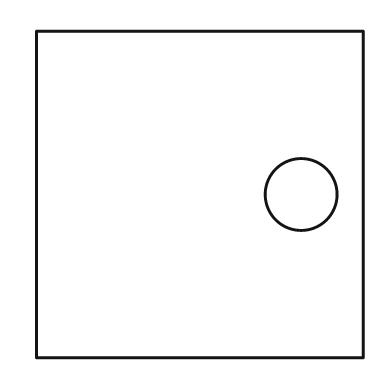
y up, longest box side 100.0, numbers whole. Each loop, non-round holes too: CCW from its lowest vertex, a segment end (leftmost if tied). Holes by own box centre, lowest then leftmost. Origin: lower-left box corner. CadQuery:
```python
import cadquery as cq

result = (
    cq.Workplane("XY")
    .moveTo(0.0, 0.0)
    .lineTo(100.0, 0.0)
    .lineTo(100.0, 100.0)
    .lineTo(0.0, 100.0)
    .close()
    .moveTo(81.0, 50.0)
    .circle(11.0)
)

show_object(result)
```